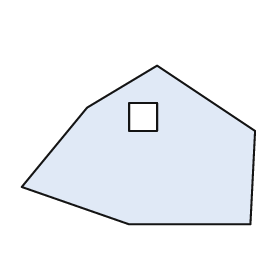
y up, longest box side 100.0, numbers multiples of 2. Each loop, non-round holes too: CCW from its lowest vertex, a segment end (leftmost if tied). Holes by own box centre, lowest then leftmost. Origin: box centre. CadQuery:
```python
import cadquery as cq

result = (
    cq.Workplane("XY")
    .moveTo(-4.0, -34.0)
    .lineTo(48.0, -34.0)
    .lineTo(50.0, 6.0)
    .lineTo(8.0, 34.0)
    .lineTo(-22.0, 16.0)
    .lineTo(-50.0, -18.0)
    .close()
    .moveTo(-4.0, 6.0)
    .lineTo(8.0, 6.0)
    .lineTo(8.0, 18.0)
    .lineTo(-4.0, 18.0)
    .close()
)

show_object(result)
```